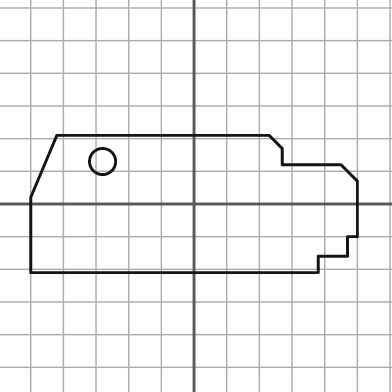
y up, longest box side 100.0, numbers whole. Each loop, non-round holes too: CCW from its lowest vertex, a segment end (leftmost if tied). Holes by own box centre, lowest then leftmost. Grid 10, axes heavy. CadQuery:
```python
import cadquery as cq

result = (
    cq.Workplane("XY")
    .moveTo(-50.0, -21.0)
    .lineTo(38.0, -21.0)
    .lineTo(38.0, -16.0)
    .lineTo(47.0, -16.0)
    .lineTo(47.0, -10.0)
    .lineTo(50.0, -10.0)
    .lineTo(50.0, 7.0)
    .lineTo(45.0, 12.0)
    .lineTo(27.0, 12.0)
    .lineTo(27.0, 17.0)
    .lineTo(23.0, 21.0)
    .lineTo(-42.0, 21.0)
    .lineTo(-50.0, 2.0)
    .close()
    .moveTo(-28.0, 13.0)
    .circle(4.0)
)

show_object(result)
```